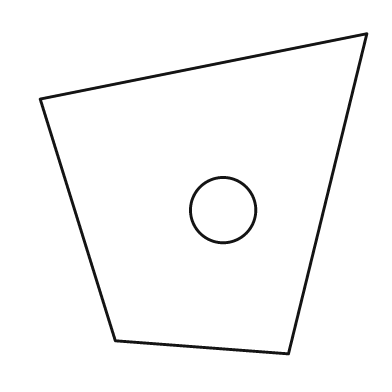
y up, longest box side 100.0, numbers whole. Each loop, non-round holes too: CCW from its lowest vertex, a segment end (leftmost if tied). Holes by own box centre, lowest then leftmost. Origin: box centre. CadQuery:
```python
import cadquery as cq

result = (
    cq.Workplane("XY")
    .moveTo(26.0, -49.0)
    .lineTo(50.0, 49.0)
    .lineTo(-50.0, 29.0)
    .lineTo(-27.0, -45.0)
    .close()
    .moveTo(6.0, -5.0)
    .circle(10.0)
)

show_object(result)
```